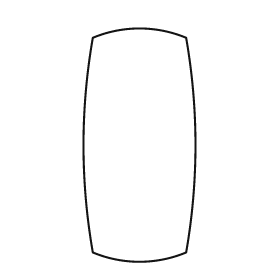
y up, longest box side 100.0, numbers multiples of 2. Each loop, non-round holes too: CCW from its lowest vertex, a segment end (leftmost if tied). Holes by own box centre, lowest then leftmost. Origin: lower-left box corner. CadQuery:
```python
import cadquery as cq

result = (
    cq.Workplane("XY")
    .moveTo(4.0, 4.0)
    .threePointArc((24.0, 0.0), (44.0, 4.0))
    .threePointArc((48.0, 50.0), (44.0, 96.0))
    .threePointArc((24.0, 100.0), (4.0, 96.0))
    .threePointArc((0.0, 50.0), (4.0, 4.0))
    .close()
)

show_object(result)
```